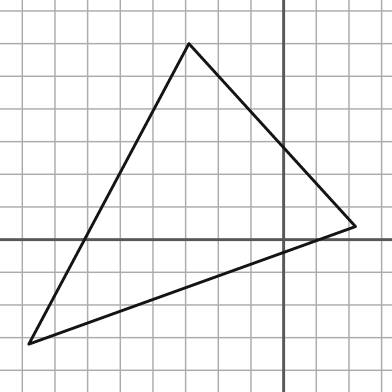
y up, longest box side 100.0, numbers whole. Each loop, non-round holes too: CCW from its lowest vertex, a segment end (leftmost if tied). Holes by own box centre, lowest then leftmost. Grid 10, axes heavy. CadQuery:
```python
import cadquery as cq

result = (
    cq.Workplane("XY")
    .moveTo(-78.0, -32.0)
    .lineTo(22.0, 4.0)
    .lineTo(-29.0, 60.0)
    .close()
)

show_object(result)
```